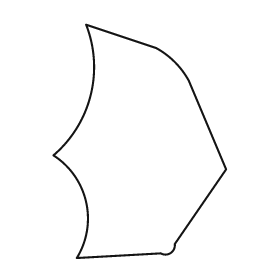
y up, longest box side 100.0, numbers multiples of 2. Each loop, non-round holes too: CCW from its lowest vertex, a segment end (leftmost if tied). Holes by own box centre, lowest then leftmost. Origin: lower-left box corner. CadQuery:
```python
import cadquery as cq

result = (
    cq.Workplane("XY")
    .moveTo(10.0, 0.0)
    .lineTo(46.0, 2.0)
    .threePointArc((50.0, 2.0), (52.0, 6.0))
    .lineTo(74.0, 38.0)
    .lineTo(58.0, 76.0)
    .threePointArc((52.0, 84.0), (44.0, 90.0))
    .lineTo(14.0, 100.0)
    .threePointArc((16.0, 70.0), (0.0, 44.0))
    .threePointArc((14.0, 24.0), (10.0, 0.0))
    .close()
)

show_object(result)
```